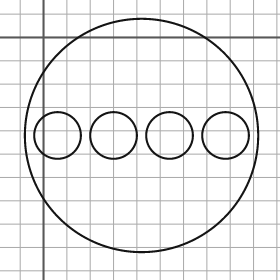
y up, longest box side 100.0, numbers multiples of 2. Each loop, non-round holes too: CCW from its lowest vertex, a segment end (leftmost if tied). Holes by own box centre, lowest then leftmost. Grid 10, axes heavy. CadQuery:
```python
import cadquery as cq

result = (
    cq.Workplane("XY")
    .moveTo(42.0, -42.0)
    .circle(50.0)
    .moveTo(6.0, -42.0)
    .circle(10.0)
    .moveTo(30.0, -42.0)
    .circle(10.0)
    .moveTo(54.0, -42.0)
    .circle(10.0)
    .moveTo(78.0, -42.0)
    .circle(10.0)
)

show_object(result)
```